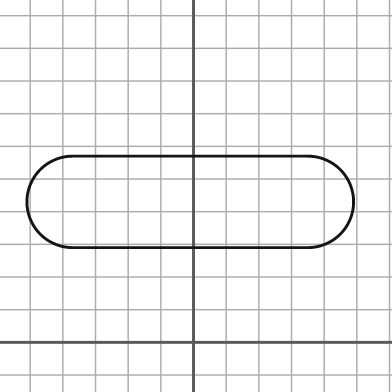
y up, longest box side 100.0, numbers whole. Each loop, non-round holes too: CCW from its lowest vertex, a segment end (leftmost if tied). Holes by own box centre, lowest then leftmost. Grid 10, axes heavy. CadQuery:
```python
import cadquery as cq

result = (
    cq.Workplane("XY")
    .moveTo(-37.0, 29.0)
    .lineTo(35.0, 29.0)
    .threePointArc((49.0, 43.0), (35.0, 57.0))
    .lineTo(-37.0, 57.0)
    .threePointArc((-51.0, 43.0), (-37.0, 29.0))
    .close()
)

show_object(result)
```